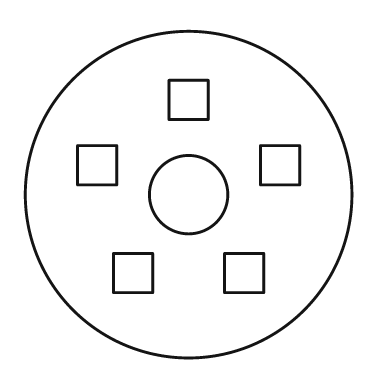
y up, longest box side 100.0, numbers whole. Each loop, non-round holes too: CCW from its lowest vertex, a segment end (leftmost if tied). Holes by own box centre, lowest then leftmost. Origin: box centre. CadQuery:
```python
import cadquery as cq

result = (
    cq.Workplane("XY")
    .moveTo(0.0, 0.0)
    .circle(50.0)
    .moveTo(-23.0, -30.0)
    .lineTo(-11.0, -30.0)
    .lineTo(-11.0, -18.0)
    .lineTo(-23.0, -18.0)
    .close()
    .moveTo(11.0, -30.0)
    .lineTo(23.0, -30.0)
    .lineTo(23.0, -18.0)
    .lineTo(11.0, -18.0)
    .close()
    .moveTo(0.0, 0.0)
    .circle(12.0)
    .moveTo(-34.0, 3.0)
    .lineTo(-22.0, 3.0)
    .lineTo(-22.0, 15.0)
    .lineTo(-34.0, 15.0)
    .close()
    .moveTo(22.0, 3.0)
    .lineTo(34.0, 3.0)
    .lineTo(34.0, 15.0)
    .lineTo(22.0, 15.0)
    .close()
    .moveTo(-6.0, 23.0)
    .lineTo(6.0, 23.0)
    .lineTo(6.0, 35.0)
    .lineTo(-6.0, 35.0)
    .close()
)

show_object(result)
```